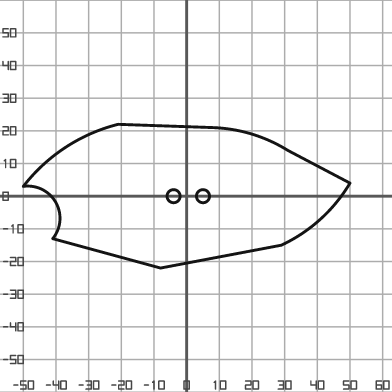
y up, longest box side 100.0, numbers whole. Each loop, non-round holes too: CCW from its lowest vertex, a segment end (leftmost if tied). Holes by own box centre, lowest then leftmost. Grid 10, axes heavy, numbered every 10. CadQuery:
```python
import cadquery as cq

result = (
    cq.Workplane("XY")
    .moveTo(-8.0, -22.0)
    .lineTo(29.0, -15.0)
    .threePointArc((41.0, -7.0), (50.0, 4.0))
    .lineTo(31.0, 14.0)
    .threePointArc((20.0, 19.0), (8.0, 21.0))
    .lineTo(-21.0, 22.0)
    .threePointArc((-37.0, 15.0), (-50.0, 3.0))
    .threePointArc((-40.0, -2.0), (-41.0, -13.0))
    .close()
    .moveTo(-4.0, 0.0)
    .circle(2.0)
    .moveTo(5.0, 0.0)
    .circle(2.0)
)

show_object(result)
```